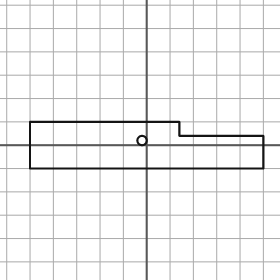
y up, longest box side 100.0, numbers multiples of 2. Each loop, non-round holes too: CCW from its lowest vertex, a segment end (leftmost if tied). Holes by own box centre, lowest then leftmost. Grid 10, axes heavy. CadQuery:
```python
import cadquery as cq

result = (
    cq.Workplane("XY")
    .moveTo(-50.0, -10.0)
    .lineTo(50.0, -10.0)
    .lineTo(50.0, 4.0)
    .lineTo(14.0, 4.0)
    .lineTo(14.0, 10.0)
    .lineTo(-50.0, 10.0)
    .close()
    .moveTo(-2.0, 2.0)
    .circle(2.0)
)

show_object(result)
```